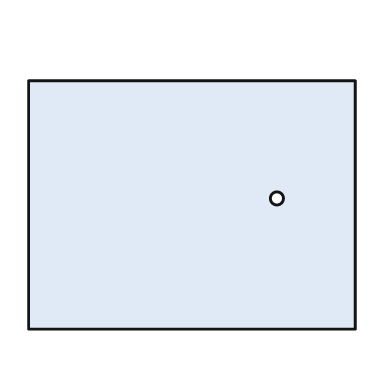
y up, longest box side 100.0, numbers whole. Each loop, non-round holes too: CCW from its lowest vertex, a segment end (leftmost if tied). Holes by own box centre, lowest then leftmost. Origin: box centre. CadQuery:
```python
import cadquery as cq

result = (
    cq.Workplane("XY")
    .moveTo(-50.0, -38.0)
    .lineTo(50.0, -38.0)
    .lineTo(50.0, 38.0)
    .lineTo(-50.0, 38.0)
    .close()
    .moveTo(26.0, 2.0)
    .circle(2.0)
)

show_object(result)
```